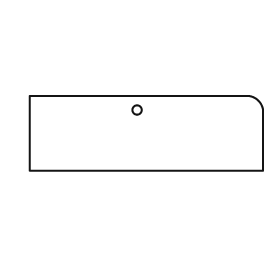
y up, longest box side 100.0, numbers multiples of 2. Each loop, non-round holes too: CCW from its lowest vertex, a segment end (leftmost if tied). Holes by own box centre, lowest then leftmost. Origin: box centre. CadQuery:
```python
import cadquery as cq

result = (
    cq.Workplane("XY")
    .moveTo(-50.0, -16.0)
    .lineTo(50.0, -16.0)
    .lineTo(50.0, 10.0)
    .threePointArc((48.0, 14.0), (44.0, 16.0))
    .lineTo(-50.0, 16.0)
    .close()
    .moveTo(-4.0, 10.0)
    .circle(2.0)
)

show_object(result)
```